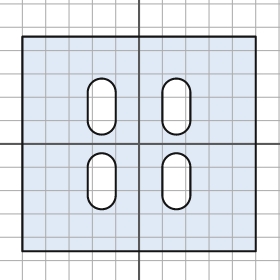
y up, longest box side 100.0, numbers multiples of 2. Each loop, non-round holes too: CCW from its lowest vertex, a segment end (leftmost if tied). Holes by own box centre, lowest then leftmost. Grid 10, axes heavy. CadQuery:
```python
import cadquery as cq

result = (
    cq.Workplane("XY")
    .moveTo(-50.0, -46.0)
    .lineTo(50.0, -46.0)
    .lineTo(50.0, 46.0)
    .lineTo(-50.0, 46.0)
    .close()
    .moveTo(-22.0, -22.0)
    .threePointArc((-16.0, -28.0), (-10.0, -22.0))
    .lineTo(-10.0, -10.0)
    .threePointArc((-16.0, -4.0), (-22.0, -10.0))
    .close()
    .moveTo(10.0, -22.0)
    .threePointArc((16.0, -28.0), (22.0, -22.0))
    .lineTo(22.0, -10.0)
    .threePointArc((16.0, -4.0), (10.0, -10.0))
    .close()
    .moveTo(-22.0, 10.0)
    .threePointArc((-16.0, 4.0), (-10.0, 10.0))
    .lineTo(-10.0, 22.0)
    .threePointArc((-16.0, 28.0), (-22.0, 22.0))
    .close()
    .moveTo(10.0, 10.0)
    .threePointArc((16.0, 4.0), (22.0, 10.0))
    .lineTo(22.0, 22.0)
    .threePointArc((16.0, 28.0), (10.0, 22.0))
    .close()
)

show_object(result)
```